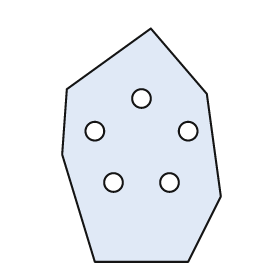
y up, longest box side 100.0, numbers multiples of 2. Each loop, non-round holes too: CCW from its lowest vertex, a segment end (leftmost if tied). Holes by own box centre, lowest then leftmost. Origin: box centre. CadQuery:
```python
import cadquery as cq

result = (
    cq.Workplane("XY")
    .moveTo(-20.0, -50.0)
    .lineTo(20.0, -50.0)
    .lineTo(34.0, -22.0)
    .lineTo(28.0, 22.0)
    .lineTo(4.0, 50.0)
    .lineTo(-32.0, 24.0)
    .lineTo(-34.0, -4.0)
    .close()
    .moveTo(-12.0, -16.0)
    .circle(4.0)
    .moveTo(12.0, -16.0)
    .circle(4.0)
    .moveTo(-20.0, 6.0)
    .circle(4.0)
    .moveTo(20.0, 6.0)
    .circle(4.0)
    .moveTo(0.0, 20.0)
    .circle(4.0)
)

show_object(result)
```